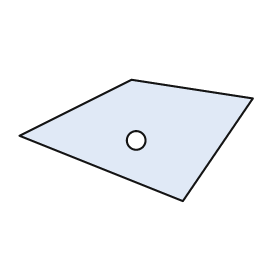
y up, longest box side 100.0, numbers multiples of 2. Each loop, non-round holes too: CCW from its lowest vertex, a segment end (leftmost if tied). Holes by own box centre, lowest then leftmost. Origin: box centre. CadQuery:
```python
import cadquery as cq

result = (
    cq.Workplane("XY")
    .moveTo(20.0, -26.0)
    .lineTo(50.0, 18.0)
    .lineTo(-2.0, 26.0)
    .lineTo(-50.0, 2.0)
    .close()
    .moveTo(0.0, 0.0)
    .circle(4.0)
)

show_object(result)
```